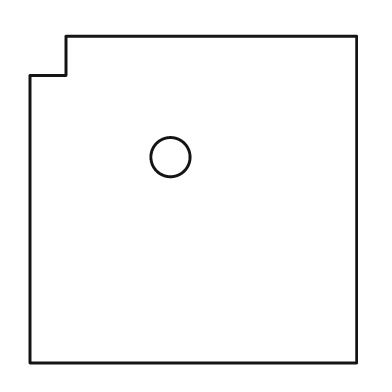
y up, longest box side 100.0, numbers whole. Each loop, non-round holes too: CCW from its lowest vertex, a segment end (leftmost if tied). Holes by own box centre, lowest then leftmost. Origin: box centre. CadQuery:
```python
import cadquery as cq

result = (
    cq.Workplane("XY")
    .moveTo(-50.0, -50.0)
    .lineTo(50.0, -50.0)
    .lineTo(50.0, 50.0)
    .lineTo(-39.0, 50.0)
    .lineTo(-39.0, 38.0)
    .lineTo(-50.0, 38.0)
    .close()
    .moveTo(-7.0, 13.0)
    .circle(6.0)
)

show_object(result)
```